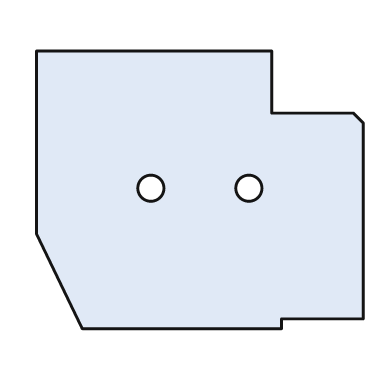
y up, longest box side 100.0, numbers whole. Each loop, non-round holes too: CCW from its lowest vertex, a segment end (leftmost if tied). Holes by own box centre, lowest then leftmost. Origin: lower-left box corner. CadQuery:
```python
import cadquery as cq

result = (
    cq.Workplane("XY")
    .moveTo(14.0, 0.0)
    .lineTo(75.0, 0.0)
    .lineTo(75.0, 3.0)
    .lineTo(100.0, 3.0)
    .lineTo(100.0, 63.0)
    .lineTo(97.0, 66.0)
    .lineTo(72.0, 66.0)
    .lineTo(72.0, 85.0)
    .lineTo(0.0, 85.0)
    .lineTo(0.0, 29.0)
    .close()
    .moveTo(35.0, 43.0)
    .circle(4.0)
    .moveTo(65.0, 43.0)
    .circle(4.0)
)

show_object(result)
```